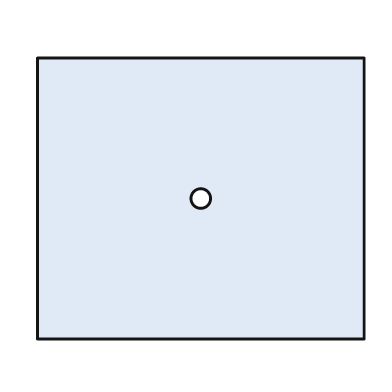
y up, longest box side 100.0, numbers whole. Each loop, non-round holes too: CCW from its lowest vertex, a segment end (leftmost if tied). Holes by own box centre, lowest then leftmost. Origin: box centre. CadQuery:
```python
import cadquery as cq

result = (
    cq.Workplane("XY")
    .moveTo(-50.0, -43.0)
    .lineTo(50.0, -43.0)
    .lineTo(50.0, 43.0)
    .lineTo(-50.0, 43.0)
    .close()
    .moveTo(0.0, 0.0)
    .circle(3.0)
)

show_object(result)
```